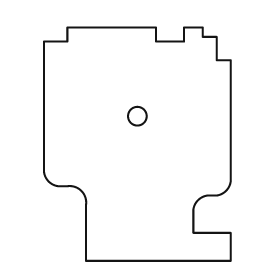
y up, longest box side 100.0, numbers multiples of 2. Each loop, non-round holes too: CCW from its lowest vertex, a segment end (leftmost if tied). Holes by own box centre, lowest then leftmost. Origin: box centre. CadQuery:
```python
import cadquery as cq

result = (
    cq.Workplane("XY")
    .moveTo(-22.0, -50.0)
    .lineTo(40.0, -50.0)
    .lineTo(40.0, -38.0)
    .lineTo(24.0, -38.0)
    .lineTo(24.0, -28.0)
    .threePointArc((26.0, -24.0), (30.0, -22.0))
    .lineTo(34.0, -22.0)
    .threePointArc((38.0, -20.0), (40.0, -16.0))
    .lineTo(40.0, 36.0)
    .lineTo(34.0, 36.0)
    .lineTo(34.0, 46.0)
    .lineTo(28.0, 46.0)
    .lineTo(28.0, 50.0)
    .lineTo(20.0, 50.0)
    .lineTo(20.0, 44.0)
    .lineTo(8.0, 44.0)
    .lineTo(8.0, 50.0)
    .lineTo(-30.0, 50.0)
    .lineTo(-30.0, 44.0)
    .lineTo(-40.0, 44.0)
    .lineTo(-40.0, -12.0)
    .threePointArc((-38.0, -16.0), (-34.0, -18.0))
    .lineTo(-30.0, -18.0)
    .threePointArc((-24.0, -20.0), (-22.0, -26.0))
    .close()
    .moveTo(0.0, 12.0)
    .circle(4.0)
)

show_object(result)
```